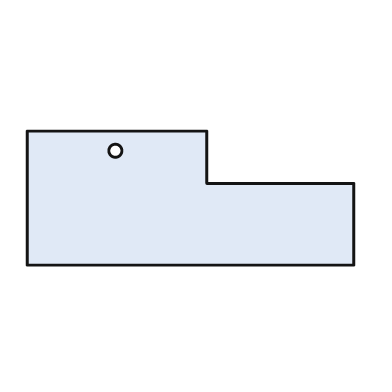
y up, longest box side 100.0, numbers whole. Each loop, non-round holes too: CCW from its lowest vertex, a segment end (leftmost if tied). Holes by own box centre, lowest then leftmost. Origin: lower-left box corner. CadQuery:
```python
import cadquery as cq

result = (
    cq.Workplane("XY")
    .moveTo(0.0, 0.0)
    .lineTo(100.0, 0.0)
    .lineTo(100.0, 25.0)
    .lineTo(55.0, 25.0)
    .lineTo(55.0, 41.0)
    .lineTo(0.0, 41.0)
    .close()
    .moveTo(27.0, 35.0)
    .circle(2.0)
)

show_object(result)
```